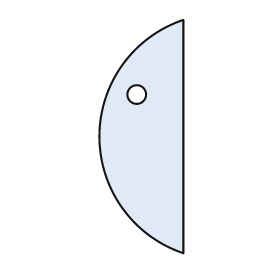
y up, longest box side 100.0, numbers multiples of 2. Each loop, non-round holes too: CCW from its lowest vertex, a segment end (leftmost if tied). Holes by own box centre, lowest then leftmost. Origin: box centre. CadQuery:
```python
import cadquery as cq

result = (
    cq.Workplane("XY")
    .moveTo(18.0, -50.0)
    .lineTo(18.0, 50.0)
    .threePointArc((-18.0, 0.0), (18.0, -50.0))
    .close()
    .moveTo(-2.0, 18.0)
    .circle(4.0)
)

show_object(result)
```